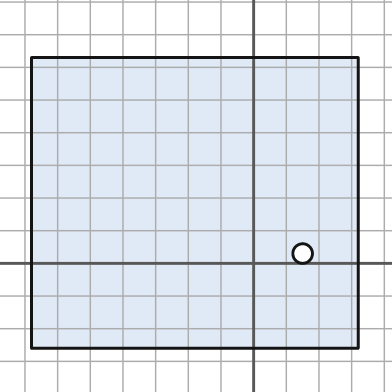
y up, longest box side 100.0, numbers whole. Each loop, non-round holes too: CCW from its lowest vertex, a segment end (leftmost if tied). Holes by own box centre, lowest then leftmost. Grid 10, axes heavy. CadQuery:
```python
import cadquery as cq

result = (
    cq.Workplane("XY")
    .moveTo(-68.0, -26.0)
    .lineTo(32.0, -26.0)
    .lineTo(32.0, 63.0)
    .lineTo(-68.0, 63.0)
    .close()
    .moveTo(15.0, 3.0)
    .circle(3.0)
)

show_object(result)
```